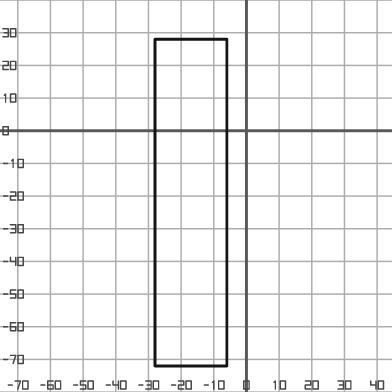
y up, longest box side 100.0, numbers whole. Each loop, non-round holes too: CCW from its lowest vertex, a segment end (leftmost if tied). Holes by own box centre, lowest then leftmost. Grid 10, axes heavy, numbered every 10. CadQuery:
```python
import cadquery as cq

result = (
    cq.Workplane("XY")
    .moveTo(-28.0, -72.0)
    .lineTo(-6.0, -72.0)
    .lineTo(-6.0, 28.0)
    .lineTo(-28.0, 28.0)
    .close()
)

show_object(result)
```